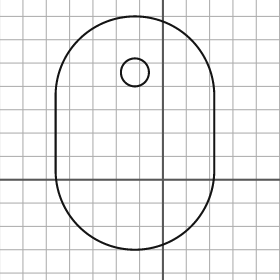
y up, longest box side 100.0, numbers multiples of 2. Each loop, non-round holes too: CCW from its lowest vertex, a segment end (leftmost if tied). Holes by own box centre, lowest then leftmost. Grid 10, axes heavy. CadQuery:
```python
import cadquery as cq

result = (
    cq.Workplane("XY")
    .moveTo(-46.0, 4.0)
    .threePointArc((-12.0, -30.0), (22.0, 4.0))
    .lineTo(22.0, 36.0)
    .threePointArc((-12.0, 70.0), (-46.0, 36.0))
    .close()
    .moveTo(-12.0, 46.0)
    .circle(6.0)
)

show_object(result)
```